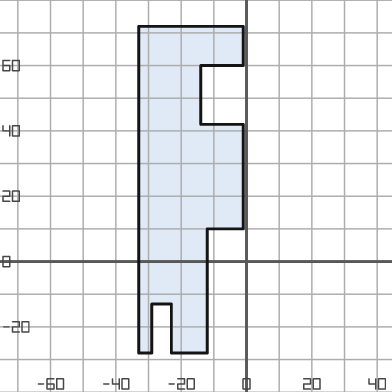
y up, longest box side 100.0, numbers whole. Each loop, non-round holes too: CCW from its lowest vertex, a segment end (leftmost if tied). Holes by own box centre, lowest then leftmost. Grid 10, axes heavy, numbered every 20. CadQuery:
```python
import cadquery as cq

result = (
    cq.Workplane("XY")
    .moveTo(-33.0, -28.0)
    .lineTo(-29.0, -28.0)
    .lineTo(-29.0, -13.0)
    .lineTo(-23.0, -13.0)
    .lineTo(-23.0, -28.0)
    .lineTo(-12.0, -28.0)
    .lineTo(-12.0, 10.0)
    .lineTo(-1.0, 10.0)
    .lineTo(-1.0, 42.0)
    .lineTo(-14.0, 42.0)
    .lineTo(-14.0, 60.0)
    .lineTo(-1.0, 60.0)
    .lineTo(-1.0, 72.0)
    .lineTo(-33.0, 72.0)
    .close()
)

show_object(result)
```